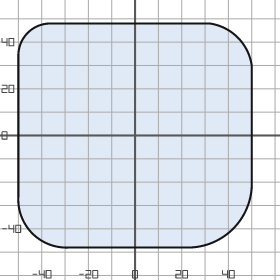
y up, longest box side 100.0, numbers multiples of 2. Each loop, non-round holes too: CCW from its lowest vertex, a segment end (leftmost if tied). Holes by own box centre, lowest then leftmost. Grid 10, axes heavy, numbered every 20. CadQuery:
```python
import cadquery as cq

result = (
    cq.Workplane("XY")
    .moveTo(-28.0, -48.0)
    .lineTo(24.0, -48.0)
    .threePointArc((42.0, -40.0), (50.0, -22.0))
    .lineTo(50.0, 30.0)
    .threePointArc((44.0, 42.0), (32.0, 48.0))
    .lineTo(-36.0, 48.0)
    .threePointArc((-46.0, 44.0), (-50.0, 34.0))
    .lineTo(-50.0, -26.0)
    .threePointArc((-44.0, -42.0), (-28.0, -48.0))
    .close()
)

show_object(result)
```